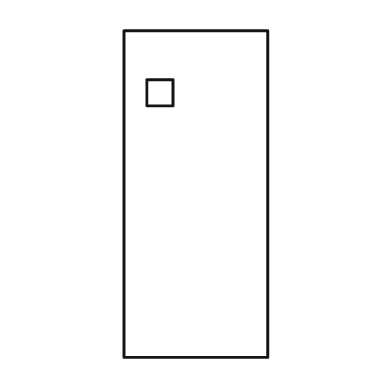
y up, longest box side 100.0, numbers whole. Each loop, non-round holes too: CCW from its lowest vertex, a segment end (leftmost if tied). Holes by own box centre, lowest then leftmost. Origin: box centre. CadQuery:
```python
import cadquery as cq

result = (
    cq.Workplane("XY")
    .moveTo(-22.0, -50.0)
    .lineTo(22.0, -50.0)
    .lineTo(22.0, 50.0)
    .lineTo(-22.0, 50.0)
    .close()
    .moveTo(-15.0, 27.0)
    .lineTo(-7.0, 27.0)
    .lineTo(-7.0, 35.0)
    .lineTo(-15.0, 35.0)
    .close()
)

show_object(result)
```